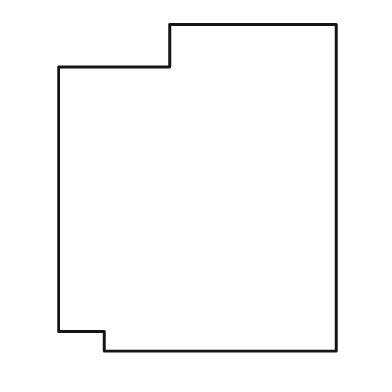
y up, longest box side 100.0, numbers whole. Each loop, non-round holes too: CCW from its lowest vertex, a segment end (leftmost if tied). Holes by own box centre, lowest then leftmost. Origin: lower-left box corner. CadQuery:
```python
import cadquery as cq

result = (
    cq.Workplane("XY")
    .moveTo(14.0, 0.0)
    .lineTo(85.0, 0.0)
    .lineTo(85.0, 100.0)
    .lineTo(34.0, 100.0)
    .lineTo(34.0, 87.0)
    .lineTo(0.0, 87.0)
    .lineTo(0.0, 6.0)
    .lineTo(14.0, 6.0)
    .close()
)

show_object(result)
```